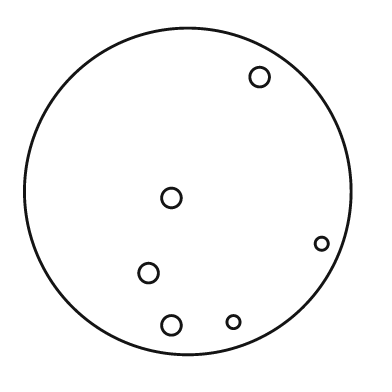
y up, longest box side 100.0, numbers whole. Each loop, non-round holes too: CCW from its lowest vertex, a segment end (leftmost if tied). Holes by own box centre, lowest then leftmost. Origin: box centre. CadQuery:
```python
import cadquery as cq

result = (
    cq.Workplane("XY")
    .moveTo(0.0, 0.0)
    .circle(50.0)
    .moveTo(-5.0, -41.0)
    .circle(3.0)
    .moveTo(14.0, -40.0)
    .circle(2.0)
    .moveTo(-12.0, -25.0)
    .circle(3.0)
    .moveTo(41.0, -16.0)
    .circle(2.0)
    .moveTo(-5.0, -2.0)
    .circle(3.0)
    .moveTo(22.0, 35.0)
    .circle(3.0)
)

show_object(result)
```